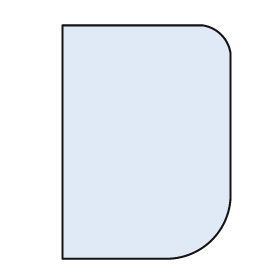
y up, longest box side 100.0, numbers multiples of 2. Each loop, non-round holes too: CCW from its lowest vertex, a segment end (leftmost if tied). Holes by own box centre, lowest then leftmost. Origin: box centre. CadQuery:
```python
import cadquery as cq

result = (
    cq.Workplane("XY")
    .moveTo(-36.0, -50.0)
    .lineTo(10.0, -50.0)
    .threePointArc((28.0, -42.0), (36.0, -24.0))
    .lineTo(36.0, 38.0)
    .threePointArc((32.0, 46.0), (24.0, 50.0))
    .lineTo(-36.0, 50.0)
    .close()
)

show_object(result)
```